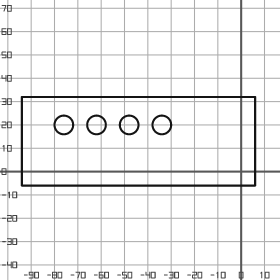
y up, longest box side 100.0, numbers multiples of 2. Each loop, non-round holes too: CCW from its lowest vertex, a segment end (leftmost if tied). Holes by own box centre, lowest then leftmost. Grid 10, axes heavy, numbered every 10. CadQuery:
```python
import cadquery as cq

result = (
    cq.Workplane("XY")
    .moveTo(-94.0, -6.0)
    .lineTo(6.0, -6.0)
    .lineTo(6.0, 32.0)
    .lineTo(-94.0, 32.0)
    .close()
    .moveTo(-76.0, 20.0)
    .circle(4.0)
    .moveTo(-62.0, 20.0)
    .circle(4.0)
    .moveTo(-48.0, 20.0)
    .circle(4.0)
    .moveTo(-34.0, 20.0)
    .circle(4.0)
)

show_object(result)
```